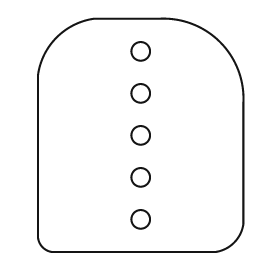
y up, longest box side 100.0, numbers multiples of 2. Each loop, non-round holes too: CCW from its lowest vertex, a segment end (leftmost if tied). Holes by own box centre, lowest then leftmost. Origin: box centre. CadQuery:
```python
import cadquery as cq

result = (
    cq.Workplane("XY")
    .moveTo(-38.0, -50.0)
    .lineTo(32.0, -50.0)
    .threePointArc((40.0, -46.0), (44.0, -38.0))
    .lineTo(44.0, 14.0)
    .threePointArc((34.0, 40.0), (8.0, 50.0))
    .lineTo(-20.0, 50.0)
    .threePointArc((-36.0, 42.0), (-44.0, 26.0))
    .lineTo(-44.0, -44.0)
    .threePointArc((-42.0, -48.0), (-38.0, -50.0))
    .close()
    .moveTo(0.0, -36.0)
    .circle(4.0)
    .moveTo(0.0, -18.0)
    .circle(4.0)
    .moveTo(0.0, 0.0)
    .circle(4.0)
    .moveTo(0.0, 18.0)
    .circle(4.0)
    .moveTo(0.0, 36.0)
    .circle(4.0)
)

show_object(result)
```